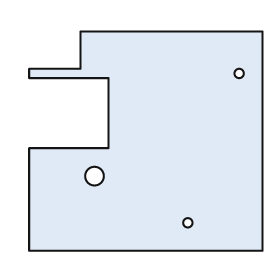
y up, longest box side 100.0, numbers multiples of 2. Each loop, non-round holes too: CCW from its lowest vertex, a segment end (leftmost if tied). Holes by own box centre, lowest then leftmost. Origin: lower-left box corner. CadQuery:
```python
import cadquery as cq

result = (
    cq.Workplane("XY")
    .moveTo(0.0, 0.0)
    .lineTo(100.0, 0.0)
    .lineTo(100.0, 94.0)
    .lineTo(22.0, 94.0)
    .lineTo(22.0, 78.0)
    .lineTo(0.0, 78.0)
    .lineTo(0.0, 74.0)
    .lineTo(34.0, 74.0)
    .lineTo(34.0, 44.0)
    .lineTo(0.0, 44.0)
    .close()
    .moveTo(68.0, 12.0)
    .circle(2.0)
    .moveTo(28.0, 32.0)
    .circle(4.0)
    .moveTo(90.0, 76.0)
    .circle(2.0)
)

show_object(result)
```